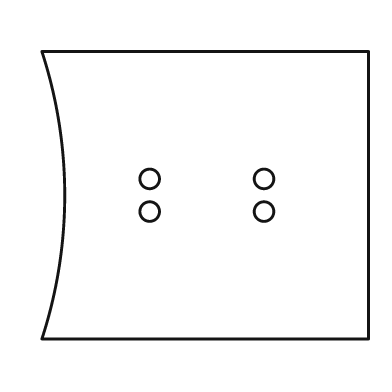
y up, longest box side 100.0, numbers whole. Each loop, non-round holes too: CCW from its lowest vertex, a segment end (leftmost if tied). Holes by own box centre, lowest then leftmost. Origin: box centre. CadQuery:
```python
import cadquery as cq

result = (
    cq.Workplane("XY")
    .moveTo(-50.0, -44.0)
    .lineTo(50.0, -44.0)
    .lineTo(50.0, 44.0)
    .lineTo(-50.0, 44.0)
    .threePointArc((-43.0, 0.0), (-50.0, -44.0))
    .close()
    .moveTo(-17.0, -5.0)
    .circle(3.0)
    .moveTo(18.0, -5.0)
    .circle(3.0)
    .moveTo(-17.0, 5.0)
    .circle(3.0)
    .moveTo(18.0, 5.0)
    .circle(3.0)
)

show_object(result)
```